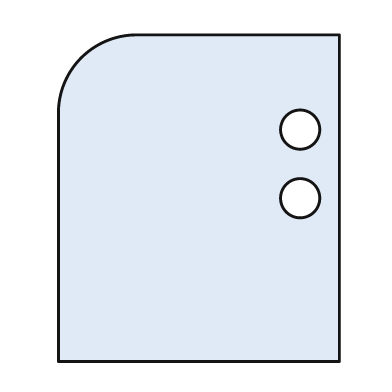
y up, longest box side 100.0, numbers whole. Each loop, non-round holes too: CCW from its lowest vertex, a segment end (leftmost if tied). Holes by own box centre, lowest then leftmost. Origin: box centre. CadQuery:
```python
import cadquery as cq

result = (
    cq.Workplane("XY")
    .moveTo(-43.0, -50.0)
    .lineTo(43.0, -50.0)
    .lineTo(43.0, 50.0)
    .lineTo(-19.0, 50.0)
    .threePointArc((-36.0, 43.0), (-43.0, 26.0))
    .close()
    .moveTo(31.0, 0.0)
    .circle(6.0)
    .moveTo(31.0, 21.0)
    .circle(6.0)
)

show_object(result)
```